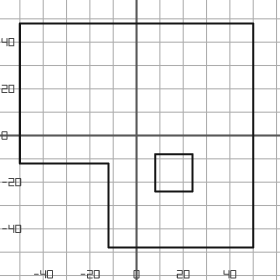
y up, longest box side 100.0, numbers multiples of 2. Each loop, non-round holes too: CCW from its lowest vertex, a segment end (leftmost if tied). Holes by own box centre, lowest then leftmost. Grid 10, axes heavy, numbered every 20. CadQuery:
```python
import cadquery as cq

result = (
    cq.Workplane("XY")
    .moveTo(-12.0, -48.0)
    .lineTo(50.0, -48.0)
    .lineTo(50.0, 48.0)
    .lineTo(-50.0, 48.0)
    .lineTo(-50.0, -12.0)
    .lineTo(-12.0, -12.0)
    .close()
    .moveTo(8.0, -24.0)
    .lineTo(24.0, -24.0)
    .lineTo(24.0, -8.0)
    .lineTo(8.0, -8.0)
    .close()
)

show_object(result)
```